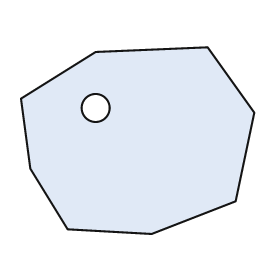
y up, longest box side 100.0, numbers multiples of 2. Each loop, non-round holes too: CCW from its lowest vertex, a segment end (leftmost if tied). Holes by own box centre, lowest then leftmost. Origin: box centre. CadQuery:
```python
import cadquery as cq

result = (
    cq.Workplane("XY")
    .moveTo(6.0, -40.0)
    .lineTo(42.0, -26.0)
    .lineTo(50.0, 12.0)
    .lineTo(30.0, 40.0)
    .lineTo(-18.0, 38.0)
    .lineTo(-50.0, 18.0)
    .lineTo(-46.0, -12.0)
    .lineTo(-30.0, -38.0)
    .close()
    .moveTo(-18.0, 14.0)
    .circle(6.0)
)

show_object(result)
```